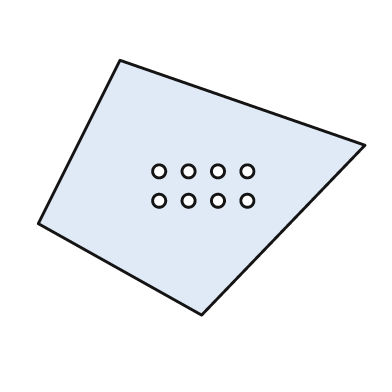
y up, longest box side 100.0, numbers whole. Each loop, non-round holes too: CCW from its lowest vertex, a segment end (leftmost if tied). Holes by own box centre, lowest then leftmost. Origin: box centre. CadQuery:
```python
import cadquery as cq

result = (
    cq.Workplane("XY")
    .moveTo(0.0, -39.0)
    .lineTo(50.0, 13.0)
    .lineTo(-25.0, 39.0)
    .lineTo(-50.0, -11.0)
    .close()
    .moveTo(-13.0, -4.0)
    .circle(2.0)
    .moveTo(-4.0, -4.0)
    .circle(2.0)
    .moveTo(5.0, -4.0)
    .circle(2.0)
    .moveTo(14.0, -4.0)
    .circle(2.0)
    .moveTo(-13.0, 5.0)
    .circle(2.0)
    .moveTo(-4.0, 5.0)
    .circle(2.0)
    .moveTo(5.0, 5.0)
    .circle(2.0)
    .moveTo(14.0, 5.0)
    .circle(2.0)
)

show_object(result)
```